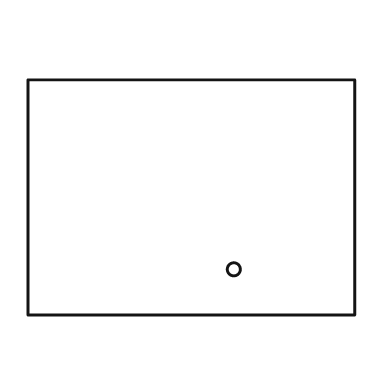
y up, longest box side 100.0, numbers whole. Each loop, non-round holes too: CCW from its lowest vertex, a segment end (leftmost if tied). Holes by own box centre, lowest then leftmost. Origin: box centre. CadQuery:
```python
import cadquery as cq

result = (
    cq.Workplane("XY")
    .moveTo(-50.0, -36.0)
    .lineTo(50.0, -36.0)
    .lineTo(50.0, 36.0)
    .lineTo(-50.0, 36.0)
    .close()
    .moveTo(13.0, -22.0)
    .circle(2.0)
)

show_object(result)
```